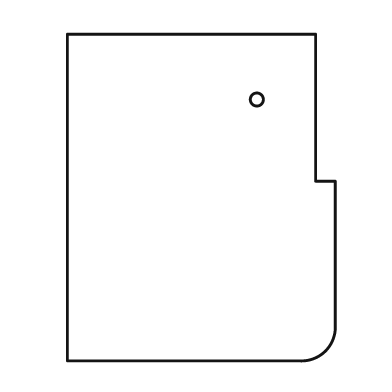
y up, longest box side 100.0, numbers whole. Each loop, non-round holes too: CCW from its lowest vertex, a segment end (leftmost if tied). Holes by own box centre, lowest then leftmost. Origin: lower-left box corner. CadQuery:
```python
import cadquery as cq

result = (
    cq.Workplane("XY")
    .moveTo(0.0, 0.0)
    .lineTo(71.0, 0.0)
    .threePointArc((79.0, 3.0), (82.0, 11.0))
    .lineTo(82.0, 55.0)
    .lineTo(76.0, 55.0)
    .lineTo(76.0, 100.0)
    .lineTo(0.0, 100.0)
    .close()
    .moveTo(58.0, 80.0)
    .circle(2.0)
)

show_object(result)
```